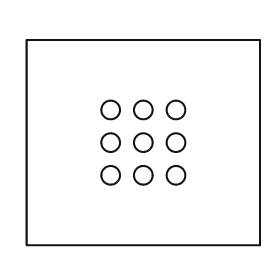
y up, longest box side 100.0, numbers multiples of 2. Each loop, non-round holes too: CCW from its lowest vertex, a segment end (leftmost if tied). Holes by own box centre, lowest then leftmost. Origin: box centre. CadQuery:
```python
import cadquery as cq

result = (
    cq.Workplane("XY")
    .moveTo(-50.0, -44.0)
    .lineTo(50.0, -44.0)
    .lineTo(50.0, 44.0)
    .lineTo(-50.0, 44.0)
    .close()
    .moveTo(-14.0, -14.0)
    .circle(4.0)
    .moveTo(0.0, -14.0)
    .circle(4.0)
    .moveTo(14.0, -14.0)
    .circle(4.0)
    .moveTo(-14.0, 0.0)
    .circle(4.0)
    .moveTo(0.0, 0.0)
    .circle(4.0)
    .moveTo(14.0, 0.0)
    .circle(4.0)
    .moveTo(-14.0, 14.0)
    .circle(4.0)
    .moveTo(0.0, 14.0)
    .circle(4.0)
    .moveTo(14.0, 14.0)
    .circle(4.0)
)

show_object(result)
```